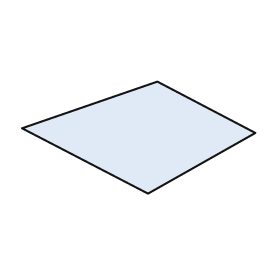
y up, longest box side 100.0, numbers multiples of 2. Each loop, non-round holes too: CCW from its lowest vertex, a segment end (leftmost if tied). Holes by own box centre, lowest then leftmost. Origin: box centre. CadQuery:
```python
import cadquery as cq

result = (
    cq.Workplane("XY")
    .moveTo(4.0, -24.0)
    .lineTo(50.0, 2.0)
    .lineTo(8.0, 24.0)
    .lineTo(-50.0, 4.0)
    .close()
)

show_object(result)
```